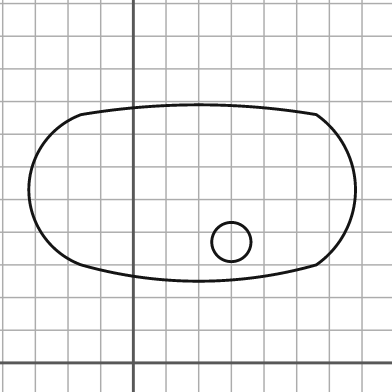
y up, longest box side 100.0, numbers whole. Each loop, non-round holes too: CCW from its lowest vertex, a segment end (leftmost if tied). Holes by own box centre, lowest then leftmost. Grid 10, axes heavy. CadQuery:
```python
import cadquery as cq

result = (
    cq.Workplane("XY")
    .moveTo(-16.0, 30.0)
    .threePointArc((20.0, 25.0), (56.0, 30.0))
    .threePointArc((68.0, 53.0), (56.0, 76.0))
    .threePointArc((20.0, 79.0), (-16.0, 76.0))
    .threePointArc((-32.0, 53.0), (-16.0, 30.0))
    .close()
    .moveTo(30.0, 37.0)
    .circle(6.0)
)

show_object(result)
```